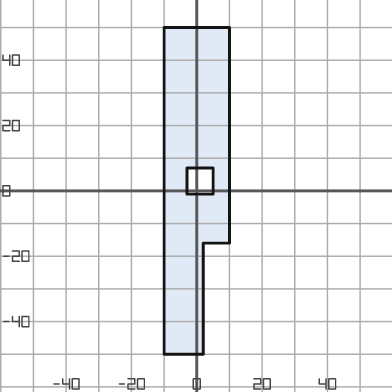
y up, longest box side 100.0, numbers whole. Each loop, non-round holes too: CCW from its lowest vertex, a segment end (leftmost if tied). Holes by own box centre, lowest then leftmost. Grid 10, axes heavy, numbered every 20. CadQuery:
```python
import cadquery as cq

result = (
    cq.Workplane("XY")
    .moveTo(-10.0, -50.0)
    .lineTo(2.0, -50.0)
    .lineTo(2.0, -16.0)
    .lineTo(10.0, -16.0)
    .lineTo(10.0, 50.0)
    .lineTo(-10.0, 50.0)
    .close()
    .moveTo(-3.0, -1.0)
    .lineTo(5.0, -1.0)
    .lineTo(5.0, 7.0)
    .lineTo(-3.0, 7.0)
    .close()
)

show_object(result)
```